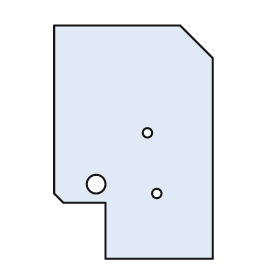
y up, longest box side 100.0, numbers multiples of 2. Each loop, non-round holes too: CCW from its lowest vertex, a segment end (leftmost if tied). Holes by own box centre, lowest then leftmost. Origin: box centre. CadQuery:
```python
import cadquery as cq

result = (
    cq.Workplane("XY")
    .moveTo(-12.0, -50.0)
    .lineTo(34.0, -50.0)
    .lineTo(34.0, 36.0)
    .lineTo(20.0, 50.0)
    .lineTo(-34.0, 50.0)
    .lineTo(-34.0, -22.0)
    .lineTo(-30.0, -26.0)
    .lineTo(-12.0, -26.0)
    .close()
    .moveTo(10.0, -22.0)
    .circle(2.0)
    .moveTo(-16.0, -18.0)
    .circle(4.0)
    .moveTo(6.0, 4.0)
    .circle(2.0)
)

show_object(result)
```